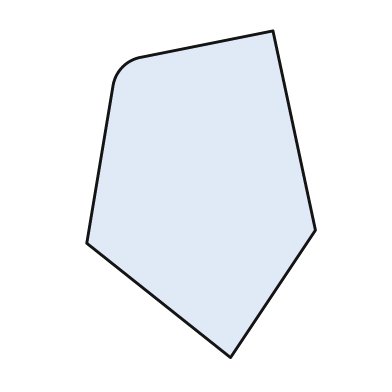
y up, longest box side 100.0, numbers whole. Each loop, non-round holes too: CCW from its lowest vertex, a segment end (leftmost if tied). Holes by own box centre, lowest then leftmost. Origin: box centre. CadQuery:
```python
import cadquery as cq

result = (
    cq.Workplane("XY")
    .moveTo(9.0, -50.0)
    .lineTo(35.0, -11.0)
    .lineTo(22.0, 50.0)
    .lineTo(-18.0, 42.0)
    .threePointArc((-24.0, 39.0), (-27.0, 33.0))
    .lineTo(-35.0, -15.0)
    .close()
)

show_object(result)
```